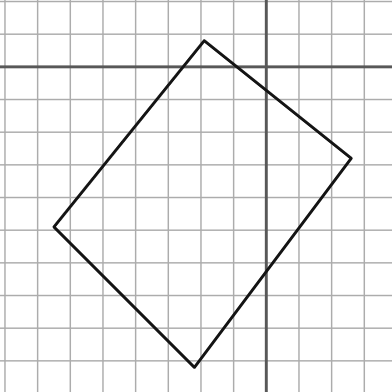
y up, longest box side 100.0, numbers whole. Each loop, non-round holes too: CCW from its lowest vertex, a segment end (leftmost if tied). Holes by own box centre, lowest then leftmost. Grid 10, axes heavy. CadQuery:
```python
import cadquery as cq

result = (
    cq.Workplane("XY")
    .moveTo(-22.0, -92.0)
    .lineTo(26.0, -28.0)
    .lineTo(-19.0, 8.0)
    .lineTo(-65.0, -49.0)
    .close()
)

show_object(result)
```